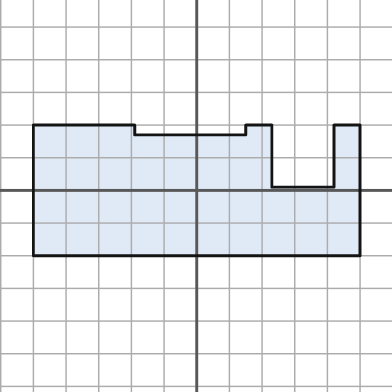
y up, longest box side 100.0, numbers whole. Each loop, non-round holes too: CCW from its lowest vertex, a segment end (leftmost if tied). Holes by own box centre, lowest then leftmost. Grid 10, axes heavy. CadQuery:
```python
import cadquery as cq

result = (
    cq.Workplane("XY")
    .moveTo(-50.0, -20.0)
    .lineTo(50.0, -20.0)
    .lineTo(50.0, 20.0)
    .lineTo(42.0, 20.0)
    .lineTo(42.0, 1.0)
    .lineTo(23.0, 1.0)
    .lineTo(23.0, 20.0)
    .lineTo(15.0, 20.0)
    .lineTo(15.0, 17.0)
    .lineTo(-19.0, 17.0)
    .lineTo(-19.0, 20.0)
    .lineTo(-50.0, 20.0)
    .close()
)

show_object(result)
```